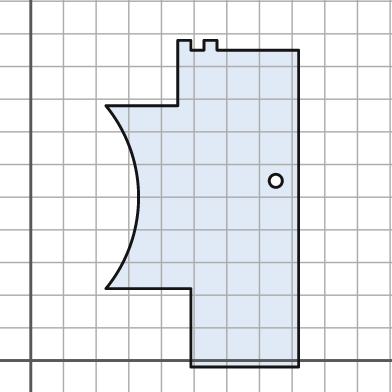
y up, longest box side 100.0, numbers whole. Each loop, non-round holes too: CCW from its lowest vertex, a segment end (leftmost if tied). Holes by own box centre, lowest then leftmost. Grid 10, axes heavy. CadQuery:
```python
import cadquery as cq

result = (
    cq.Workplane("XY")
    .moveTo(49.0, -2.0)
    .lineTo(82.0, -2.0)
    .lineTo(82.0, 95.0)
    .lineTo(57.0, 95.0)
    .lineTo(57.0, 98.0)
    .lineTo(53.0, 98.0)
    .lineTo(53.0, 95.0)
    .lineTo(49.0, 95.0)
    .lineTo(49.0, 98.0)
    .lineTo(45.0, 98.0)
    .lineTo(45.0, 78.0)
    .lineTo(23.0, 78.0)
    .threePointArc((33.0, 50.0), (23.0, 22.0))
    .lineTo(49.0, 22.0)
    .close()
    .moveTo(75.0, 55.0)
    .circle(2.0)
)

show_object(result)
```